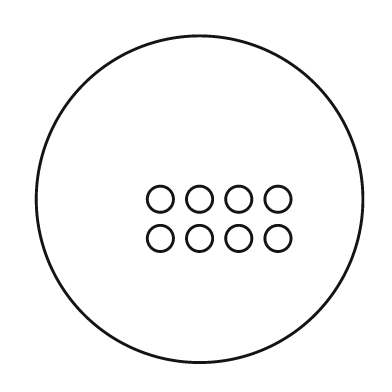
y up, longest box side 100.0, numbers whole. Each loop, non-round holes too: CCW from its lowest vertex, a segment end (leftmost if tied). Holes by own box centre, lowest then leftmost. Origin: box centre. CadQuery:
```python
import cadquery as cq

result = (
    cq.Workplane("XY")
    .moveTo(0.0, 0.0)
    .circle(50.0)
    .moveTo(-12.0, -12.0)
    .circle(4.0)
    .moveTo(0.0, -12.0)
    .circle(4.0)
    .moveTo(12.0, -12.0)
    .circle(4.0)
    .moveTo(24.0, -12.0)
    .circle(4.0)
    .moveTo(-12.0, 0.0)
    .circle(4.0)
    .moveTo(0.0, 0.0)
    .circle(4.0)
    .moveTo(12.0, 0.0)
    .circle(4.0)
    .moveTo(24.0, 0.0)
    .circle(4.0)
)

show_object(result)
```